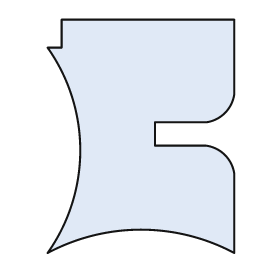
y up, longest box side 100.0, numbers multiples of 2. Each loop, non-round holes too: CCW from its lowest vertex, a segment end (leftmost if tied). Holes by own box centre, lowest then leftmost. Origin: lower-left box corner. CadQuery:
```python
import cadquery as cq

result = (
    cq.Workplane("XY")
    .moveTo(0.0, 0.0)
    .threePointArc((40.0, 10.0), (80.0, 0.0))
    .lineTo(80.0, 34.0)
    .threePointArc((76.0, 42.0), (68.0, 46.0))
    .lineTo(46.0, 46.0)
    .lineTo(46.0, 56.0)
    .lineTo(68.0, 56.0)
    .threePointArc((76.0, 60.0), (80.0, 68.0))
    .lineTo(80.0, 100.0)
    .lineTo(6.0, 100.0)
    .lineTo(6.0, 88.0)
    .lineTo(0.0, 88.0)
    .threePointArc((14.0, 44.0), (0.0, 0.0))
    .close()
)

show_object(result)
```